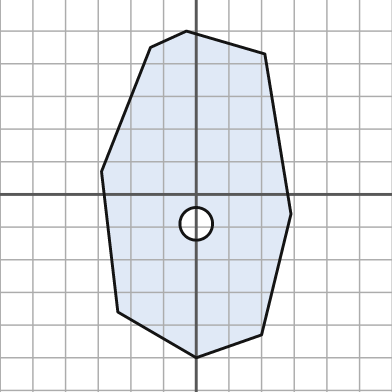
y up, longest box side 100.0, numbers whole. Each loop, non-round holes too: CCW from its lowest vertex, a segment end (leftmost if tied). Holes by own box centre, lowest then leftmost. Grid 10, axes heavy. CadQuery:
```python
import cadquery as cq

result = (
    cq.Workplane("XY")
    .moveTo(0.0, -50.0)
    .lineTo(20.0, -43.0)
    .lineTo(29.0, -6.0)
    .lineTo(21.0, 43.0)
    .lineTo(-3.0, 50.0)
    .lineTo(-14.0, 45.0)
    .lineTo(-29.0, 7.0)
    .lineTo(-24.0, -36.0)
    .close()
    .moveTo(0.0, -9.0)
    .circle(5.0)
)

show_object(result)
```